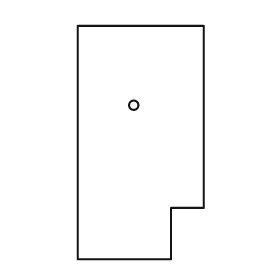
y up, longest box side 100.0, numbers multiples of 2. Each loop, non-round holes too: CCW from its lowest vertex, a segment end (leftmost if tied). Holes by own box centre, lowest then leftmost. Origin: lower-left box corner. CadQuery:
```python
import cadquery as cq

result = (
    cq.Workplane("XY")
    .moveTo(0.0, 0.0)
    .lineTo(40.0, 0.0)
    .lineTo(40.0, 22.0)
    .lineTo(54.0, 22.0)
    .lineTo(54.0, 100.0)
    .lineTo(0.0, 100.0)
    .close()
    .moveTo(24.0, 66.0)
    .circle(2.0)
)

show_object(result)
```